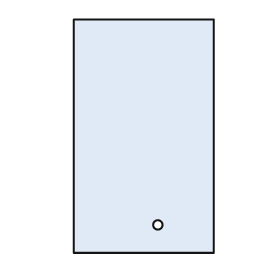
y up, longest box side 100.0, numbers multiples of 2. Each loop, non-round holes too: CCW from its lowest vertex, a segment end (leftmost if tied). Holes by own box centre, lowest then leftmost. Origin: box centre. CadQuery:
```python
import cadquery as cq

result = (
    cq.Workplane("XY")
    .moveTo(-30.0, -50.0)
    .lineTo(30.0, -50.0)
    .lineTo(30.0, 50.0)
    .lineTo(-30.0, 50.0)
    .close()
    .moveTo(6.0, -38.0)
    .circle(2.0)
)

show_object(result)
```